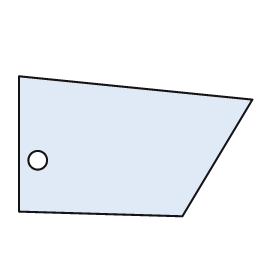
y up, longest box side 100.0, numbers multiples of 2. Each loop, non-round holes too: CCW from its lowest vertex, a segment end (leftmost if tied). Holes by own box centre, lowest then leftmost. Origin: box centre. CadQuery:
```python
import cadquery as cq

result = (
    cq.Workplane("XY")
    .moveTo(20.0, -30.0)
    .lineTo(50.0, 20.0)
    .lineTo(-50.0, 30.0)
    .lineTo(-50.0, -28.0)
    .close()
    .moveTo(-42.0, -6.0)
    .circle(4.0)
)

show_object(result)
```